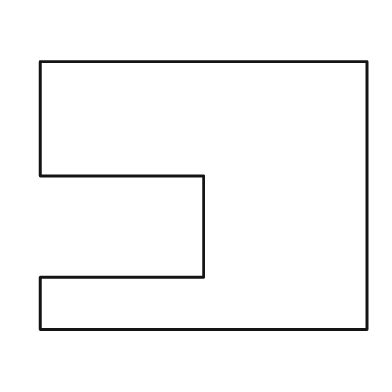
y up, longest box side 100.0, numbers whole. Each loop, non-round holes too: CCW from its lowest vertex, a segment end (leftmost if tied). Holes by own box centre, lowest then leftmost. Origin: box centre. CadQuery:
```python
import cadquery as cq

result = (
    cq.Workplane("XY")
    .moveTo(-50.0, -41.0)
    .lineTo(50.0, -41.0)
    .lineTo(50.0, 41.0)
    .lineTo(-50.0, 41.0)
    .lineTo(-50.0, 6.0)
    .lineTo(0.0, 6.0)
    .lineTo(0.0, -25.0)
    .lineTo(-50.0, -25.0)
    .close()
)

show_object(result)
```